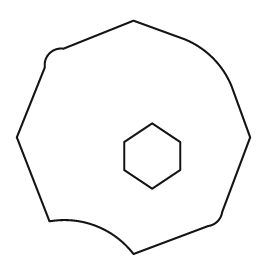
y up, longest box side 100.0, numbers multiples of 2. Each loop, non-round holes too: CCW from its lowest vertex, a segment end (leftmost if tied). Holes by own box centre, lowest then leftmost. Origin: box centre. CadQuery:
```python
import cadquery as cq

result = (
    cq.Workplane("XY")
    .moveTo(0.0, -50.0)
    .lineTo(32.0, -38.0)
    .threePointArc((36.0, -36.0), (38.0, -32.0))
    .lineTo(50.0, 0.0)
    .lineTo(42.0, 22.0)
    .threePointArc((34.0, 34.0), (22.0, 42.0))
    .lineTo(0.0, 50.0)
    .lineTo(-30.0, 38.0)
    .threePointArc((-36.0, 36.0), (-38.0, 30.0))
    .lineTo(-50.0, 0.0)
    .lineTo(-36.0, -36.0)
    .threePointArc((-16.0, -38.0), (0.0, -50.0))
    .close()
    .moveTo(8.0, -22.0)
    .lineTo(20.0, -14.0)
    .lineTo(20.0, -2.0)
    .lineTo(8.0, 6.0)
    .lineTo(-4.0, -2.0)
    .lineTo(-4.0, -14.0)
    .close()
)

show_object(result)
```